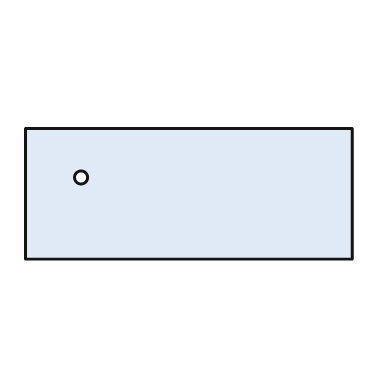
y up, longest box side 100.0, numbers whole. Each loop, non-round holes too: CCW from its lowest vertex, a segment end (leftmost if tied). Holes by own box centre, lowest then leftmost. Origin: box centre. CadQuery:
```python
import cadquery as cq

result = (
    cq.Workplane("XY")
    .moveTo(-50.0, -20.0)
    .lineTo(50.0, -20.0)
    .lineTo(50.0, 20.0)
    .lineTo(-50.0, 20.0)
    .close()
    .moveTo(-33.0, 5.0)
    .circle(2.0)
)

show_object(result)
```